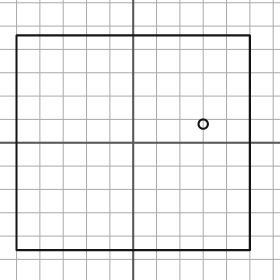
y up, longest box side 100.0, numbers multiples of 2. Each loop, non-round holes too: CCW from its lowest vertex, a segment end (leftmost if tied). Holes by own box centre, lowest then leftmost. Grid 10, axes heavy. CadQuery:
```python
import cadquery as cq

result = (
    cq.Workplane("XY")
    .moveTo(-50.0, -46.0)
    .lineTo(50.0, -46.0)
    .lineTo(50.0, 46.0)
    .lineTo(-50.0, 46.0)
    .close()
    .moveTo(30.0, 8.0)
    .circle(2.0)
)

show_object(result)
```